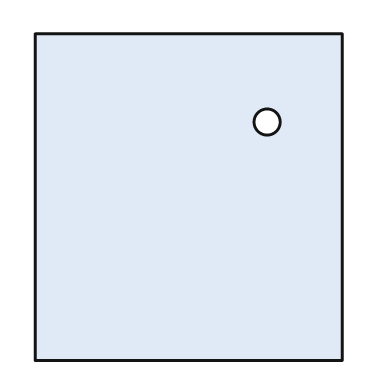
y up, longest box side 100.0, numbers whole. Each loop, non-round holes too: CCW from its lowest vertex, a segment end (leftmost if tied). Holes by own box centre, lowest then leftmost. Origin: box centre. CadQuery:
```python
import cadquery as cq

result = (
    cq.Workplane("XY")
    .moveTo(-47.0, -50.0)
    .lineTo(47.0, -50.0)
    .lineTo(47.0, 50.0)
    .lineTo(-47.0, 50.0)
    .close()
    .moveTo(24.0, 23.0)
    .circle(4.0)
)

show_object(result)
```